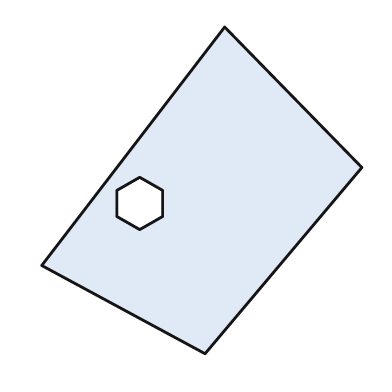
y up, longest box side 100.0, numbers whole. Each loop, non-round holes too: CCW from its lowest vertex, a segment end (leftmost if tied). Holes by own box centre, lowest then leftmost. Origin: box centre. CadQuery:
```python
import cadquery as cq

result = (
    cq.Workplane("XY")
    .moveTo(1.0, -50.0)
    .lineTo(49.0, 7.0)
    .lineTo(7.0, 50.0)
    .lineTo(-49.0, -23.0)
    .close()
    .moveTo(-19.0, -12.0)
    .lineTo(-12.0, -8.0)
    .lineTo(-12.0, 0.0)
    .lineTo(-19.0, 4.0)
    .lineTo(-26.0, 0.0)
    .lineTo(-26.0, -8.0)
    .close()
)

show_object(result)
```